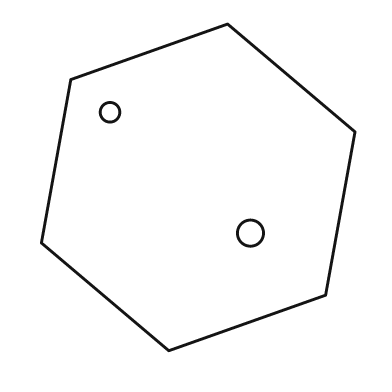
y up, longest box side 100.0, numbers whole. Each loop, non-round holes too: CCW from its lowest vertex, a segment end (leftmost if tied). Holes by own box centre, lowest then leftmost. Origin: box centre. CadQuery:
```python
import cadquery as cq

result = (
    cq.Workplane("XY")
    .moveTo(-9.0, -50.0)
    .lineTo(39.0, -33.0)
    .lineTo(48.0, 17.0)
    .lineTo(9.0, 50.0)
    .lineTo(-39.0, 33.0)
    .lineTo(-48.0, -17.0)
    .close()
    .moveTo(16.0, -14.0)
    .circle(4.0)
    .moveTo(-27.0, 23.0)
    .circle(3.0)
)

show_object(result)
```